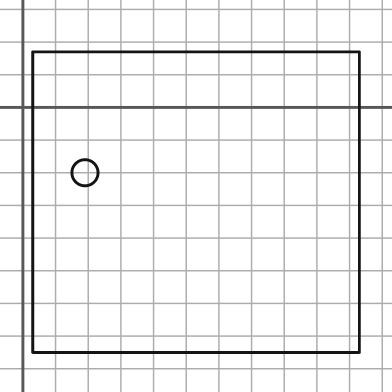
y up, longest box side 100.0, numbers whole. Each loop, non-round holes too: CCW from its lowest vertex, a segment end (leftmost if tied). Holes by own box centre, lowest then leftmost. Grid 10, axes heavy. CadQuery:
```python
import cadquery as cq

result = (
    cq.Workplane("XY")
    .moveTo(3.0, -75.0)
    .lineTo(103.0, -75.0)
    .lineTo(103.0, 17.0)
    .lineTo(3.0, 17.0)
    .close()
    .moveTo(19.0, -20.0)
    .circle(4.0)
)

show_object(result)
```